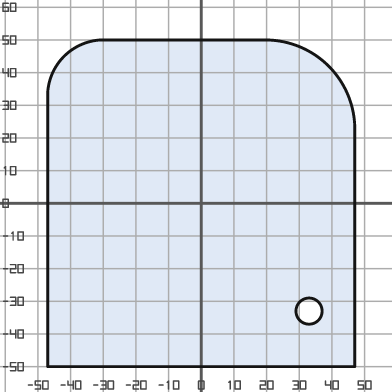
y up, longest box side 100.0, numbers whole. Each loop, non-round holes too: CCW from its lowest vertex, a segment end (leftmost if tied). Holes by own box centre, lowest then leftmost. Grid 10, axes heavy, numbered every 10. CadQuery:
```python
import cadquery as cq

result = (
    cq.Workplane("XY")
    .moveTo(-47.0, -50.0)
    .lineTo(47.0, -50.0)
    .lineTo(47.0, 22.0)
    .threePointArc((39.0, 42.0), (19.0, 50.0))
    .lineTo(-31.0, 50.0)
    .threePointArc((-42.0, 45.0), (-47.0, 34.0))
    .close()
    .moveTo(33.0, -33.0)
    .circle(4.0)
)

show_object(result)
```